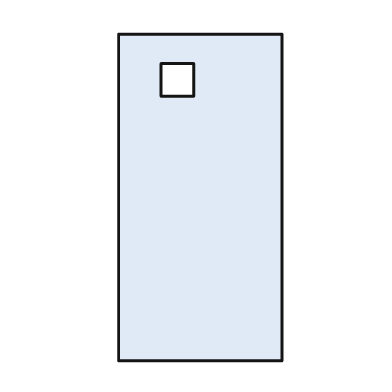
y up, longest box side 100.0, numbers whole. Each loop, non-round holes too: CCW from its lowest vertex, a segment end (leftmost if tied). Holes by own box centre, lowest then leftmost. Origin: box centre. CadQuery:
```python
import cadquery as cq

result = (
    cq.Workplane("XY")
    .moveTo(-25.0, -50.0)
    .lineTo(25.0, -50.0)
    .lineTo(25.0, 50.0)
    .lineTo(-25.0, 50.0)
    .close()
    .moveTo(-12.0, 31.0)
    .lineTo(-2.0, 31.0)
    .lineTo(-2.0, 41.0)
    .lineTo(-12.0, 41.0)
    .close()
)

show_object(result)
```